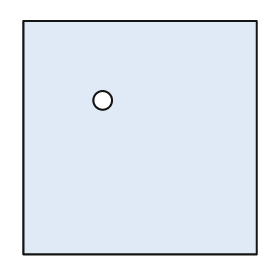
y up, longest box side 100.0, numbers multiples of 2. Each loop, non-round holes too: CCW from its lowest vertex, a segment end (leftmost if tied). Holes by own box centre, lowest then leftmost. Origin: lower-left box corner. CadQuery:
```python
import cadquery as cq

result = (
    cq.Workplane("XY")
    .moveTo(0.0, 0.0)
    .lineTo(100.0, 0.0)
    .lineTo(100.0, 100.0)
    .lineTo(0.0, 100.0)
    .close()
    .moveTo(34.0, 66.0)
    .circle(4.0)
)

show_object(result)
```